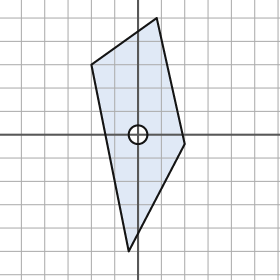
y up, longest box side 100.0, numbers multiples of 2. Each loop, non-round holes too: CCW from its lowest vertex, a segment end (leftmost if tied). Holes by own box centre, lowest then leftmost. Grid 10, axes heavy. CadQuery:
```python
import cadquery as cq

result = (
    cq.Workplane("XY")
    .moveTo(-4.0, -50.0)
    .lineTo(20.0, -4.0)
    .lineTo(8.0, 50.0)
    .lineTo(-20.0, 30.0)
    .close()
    .moveTo(0.0, 0.0)
    .circle(4.0)
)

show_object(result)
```